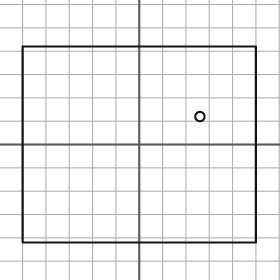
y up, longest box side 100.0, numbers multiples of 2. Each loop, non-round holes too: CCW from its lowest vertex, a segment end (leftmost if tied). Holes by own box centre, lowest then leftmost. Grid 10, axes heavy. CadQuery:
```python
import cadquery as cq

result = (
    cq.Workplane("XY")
    .moveTo(-50.0, -42.0)
    .lineTo(50.0, -42.0)
    .lineTo(50.0, 42.0)
    .lineTo(-50.0, 42.0)
    .close()
    .moveTo(26.0, 12.0)
    .circle(2.0)
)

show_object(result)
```